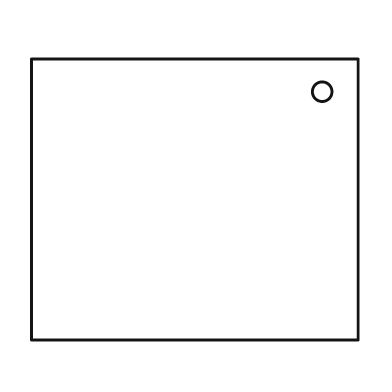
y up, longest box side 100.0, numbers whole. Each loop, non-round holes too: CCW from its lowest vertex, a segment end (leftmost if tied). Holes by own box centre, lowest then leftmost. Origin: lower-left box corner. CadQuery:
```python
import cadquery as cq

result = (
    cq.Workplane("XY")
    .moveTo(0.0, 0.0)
    .lineTo(100.0, 0.0)
    .lineTo(100.0, 86.0)
    .lineTo(0.0, 86.0)
    .close()
    .moveTo(89.0, 76.0)
    .circle(3.0)
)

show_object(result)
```